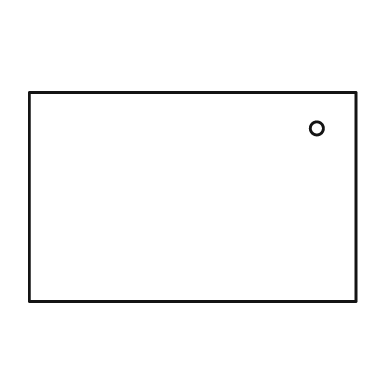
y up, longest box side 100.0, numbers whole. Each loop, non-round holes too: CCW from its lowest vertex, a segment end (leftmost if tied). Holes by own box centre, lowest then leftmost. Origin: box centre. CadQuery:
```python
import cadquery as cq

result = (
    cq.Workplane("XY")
    .moveTo(-50.0, -32.0)
    .lineTo(50.0, -32.0)
    .lineTo(50.0, 32.0)
    .lineTo(-50.0, 32.0)
    .close()
    .moveTo(38.0, 21.0)
    .circle(2.0)
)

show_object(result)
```